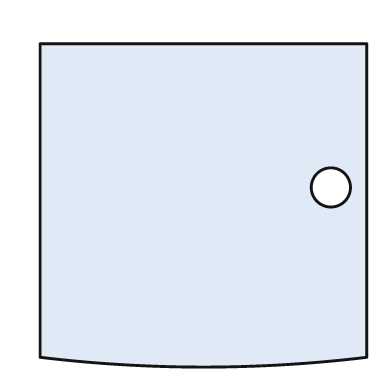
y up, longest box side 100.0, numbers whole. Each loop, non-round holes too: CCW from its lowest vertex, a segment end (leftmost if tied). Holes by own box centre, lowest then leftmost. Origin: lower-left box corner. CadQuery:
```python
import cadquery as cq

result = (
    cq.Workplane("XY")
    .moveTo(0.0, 3.0)
    .threePointArc((50.0, 0.0), (100.0, 3.0))
    .lineTo(100.0, 99.0)
    .lineTo(0.0, 99.0)
    .close()
    .moveTo(89.0, 55.0)
    .circle(6.0)
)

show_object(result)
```